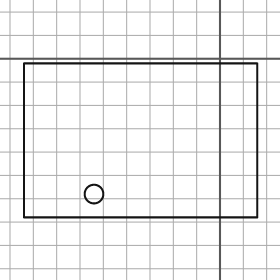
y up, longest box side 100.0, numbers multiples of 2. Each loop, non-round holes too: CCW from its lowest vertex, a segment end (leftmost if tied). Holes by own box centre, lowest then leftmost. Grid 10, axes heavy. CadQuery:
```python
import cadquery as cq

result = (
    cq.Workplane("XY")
    .moveTo(-84.0, -68.0)
    .lineTo(16.0, -68.0)
    .lineTo(16.0, -2.0)
    .lineTo(-84.0, -2.0)
    .close()
    .moveTo(-54.0, -58.0)
    .circle(4.0)
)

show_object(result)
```